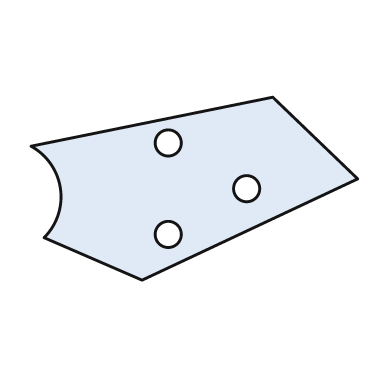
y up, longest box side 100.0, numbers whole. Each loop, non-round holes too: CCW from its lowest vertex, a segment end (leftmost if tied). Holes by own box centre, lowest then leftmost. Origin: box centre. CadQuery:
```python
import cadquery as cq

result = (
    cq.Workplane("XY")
    .moveTo(-16.0, -28.0)
    .lineTo(50.0, 3.0)
    .lineTo(24.0, 28.0)
    .lineTo(-50.0, 13.0)
    .threePointArc((-41.0, 0.0), (-46.0, -15.0))
    .close()
    .moveTo(-8.0, -14.0)
    .circle(4.0)
    .moveTo(16.0, 0.0)
    .circle(4.0)
    .moveTo(-8.0, 14.0)
    .circle(4.0)
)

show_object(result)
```